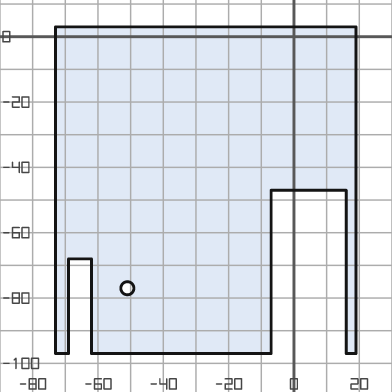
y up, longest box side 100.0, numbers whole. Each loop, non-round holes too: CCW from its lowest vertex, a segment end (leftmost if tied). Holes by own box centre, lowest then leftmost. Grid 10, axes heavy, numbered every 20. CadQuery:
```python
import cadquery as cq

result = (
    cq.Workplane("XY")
    .moveTo(-73.0, -97.0)
    .lineTo(-69.0, -97.0)
    .lineTo(-69.0, -68.0)
    .lineTo(-62.0, -68.0)
    .lineTo(-62.0, -97.0)
    .lineTo(-7.0, -97.0)
    .lineTo(-7.0, -47.0)
    .lineTo(16.0, -47.0)
    .lineTo(16.0, -97.0)
    .lineTo(19.0, -97.0)
    .lineTo(19.0, 3.0)
    .lineTo(-73.0, 3.0)
    .close()
    .moveTo(-51.0, -77.0)
    .circle(2.0)
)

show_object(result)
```